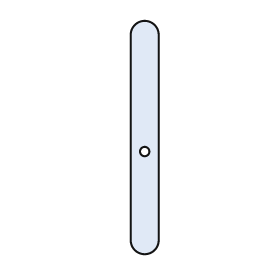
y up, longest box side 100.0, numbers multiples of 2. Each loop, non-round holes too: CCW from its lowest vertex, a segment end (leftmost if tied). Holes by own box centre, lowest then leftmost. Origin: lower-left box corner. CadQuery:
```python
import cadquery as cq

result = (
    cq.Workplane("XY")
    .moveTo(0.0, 6.0)
    .threePointArc((6.0, 0.0), (12.0, 6.0))
    .lineTo(12.0, 94.0)
    .threePointArc((6.0, 100.0), (0.0, 94.0))
    .close()
    .moveTo(6.0, 44.0)
    .circle(2.0)
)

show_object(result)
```